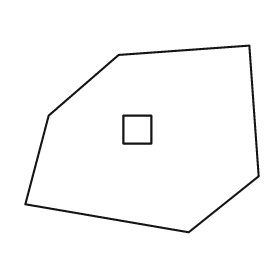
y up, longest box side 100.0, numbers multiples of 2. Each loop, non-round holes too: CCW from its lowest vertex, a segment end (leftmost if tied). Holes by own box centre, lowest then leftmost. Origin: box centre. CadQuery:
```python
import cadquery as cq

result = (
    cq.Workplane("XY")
    .moveTo(20.0, -40.0)
    .lineTo(50.0, -16.0)
    .lineTo(46.0, 40.0)
    .lineTo(-10.0, 36.0)
    .lineTo(-40.0, 10.0)
    .lineTo(-50.0, -28.0)
    .close()
    .moveTo(-8.0, -2.0)
    .lineTo(4.0, -2.0)
    .lineTo(4.0, 10.0)
    .lineTo(-8.0, 10.0)
    .close()
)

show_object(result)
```